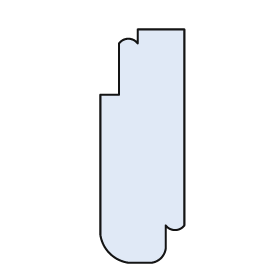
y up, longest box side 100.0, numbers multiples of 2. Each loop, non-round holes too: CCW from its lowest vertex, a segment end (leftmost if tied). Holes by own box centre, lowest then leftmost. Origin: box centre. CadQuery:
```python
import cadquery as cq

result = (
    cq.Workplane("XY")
    .moveTo(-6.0, -50.0)
    .lineTo(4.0, -50.0)
    .threePointArc((8.0, -48.0), (10.0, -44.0))
    .lineTo(10.0, -34.0)
    .threePointArc((14.0, -36.0), (18.0, -34.0))
    .lineTo(18.0, 50.0)
    .lineTo(-2.0, 50.0)
    .lineTo(-2.0, 44.0)
    .threePointArc((-6.0, 46.0), (-10.0, 44.0))
    .lineTo(-10.0, 22.0)
    .lineTo(-18.0, 22.0)
    .lineTo(-18.0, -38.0)
    .threePointArc((-14.0, -46.0), (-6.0, -50.0))
    .close()
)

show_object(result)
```